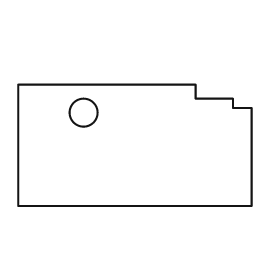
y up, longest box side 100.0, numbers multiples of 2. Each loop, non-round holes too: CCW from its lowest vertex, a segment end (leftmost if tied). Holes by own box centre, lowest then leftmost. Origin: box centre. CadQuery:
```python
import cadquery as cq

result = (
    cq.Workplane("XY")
    .moveTo(-50.0, -26.0)
    .lineTo(50.0, -26.0)
    .lineTo(50.0, 16.0)
    .lineTo(42.0, 16.0)
    .lineTo(42.0, 20.0)
    .lineTo(26.0, 20.0)
    .lineTo(26.0, 26.0)
    .lineTo(-50.0, 26.0)
    .close()
    .moveTo(-22.0, 14.0)
    .circle(6.0)
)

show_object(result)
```